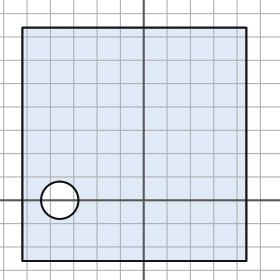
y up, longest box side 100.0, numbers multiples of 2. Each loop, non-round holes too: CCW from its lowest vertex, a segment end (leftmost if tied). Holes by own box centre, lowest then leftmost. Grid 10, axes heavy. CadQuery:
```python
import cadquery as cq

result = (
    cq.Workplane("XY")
    .moveTo(-52.0, -26.0)
    .lineTo(44.0, -26.0)
    .lineTo(44.0, 74.0)
    .lineTo(-52.0, 74.0)
    .close()
    .moveTo(-36.0, 0.0)
    .circle(8.0)
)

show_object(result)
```